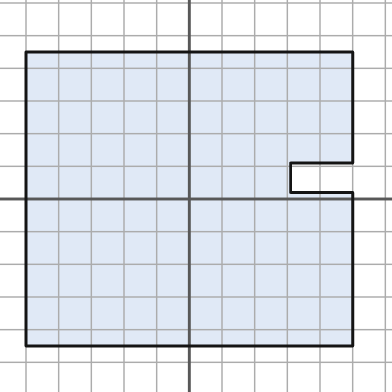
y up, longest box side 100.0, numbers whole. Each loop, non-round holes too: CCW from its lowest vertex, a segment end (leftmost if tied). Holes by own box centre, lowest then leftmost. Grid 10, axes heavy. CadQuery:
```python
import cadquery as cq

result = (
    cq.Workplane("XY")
    .moveTo(-50.0, -45.0)
    .lineTo(50.0, -45.0)
    .lineTo(50.0, 2.0)
    .lineTo(31.0, 2.0)
    .lineTo(31.0, 11.0)
    .lineTo(50.0, 11.0)
    .lineTo(50.0, 45.0)
    .lineTo(-50.0, 45.0)
    .close()
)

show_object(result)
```